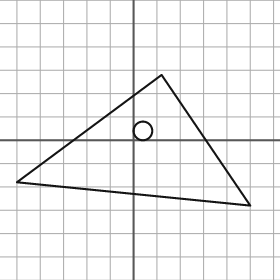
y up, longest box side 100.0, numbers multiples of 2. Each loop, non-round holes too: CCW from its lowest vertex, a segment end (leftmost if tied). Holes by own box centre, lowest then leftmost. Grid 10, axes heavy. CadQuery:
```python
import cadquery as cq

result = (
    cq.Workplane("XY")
    .moveTo(50.0, -28.0)
    .lineTo(12.0, 28.0)
    .lineTo(-50.0, -18.0)
    .close()
    .moveTo(4.0, 4.0)
    .circle(4.0)
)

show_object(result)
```